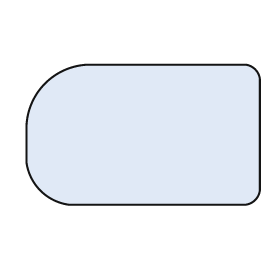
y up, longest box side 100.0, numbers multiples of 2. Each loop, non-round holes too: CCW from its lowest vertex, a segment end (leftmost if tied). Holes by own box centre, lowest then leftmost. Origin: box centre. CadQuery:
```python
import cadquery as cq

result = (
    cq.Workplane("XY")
    .moveTo(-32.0, -30.0)
    .lineTo(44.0, -30.0)
    .threePointArc((48.0, -28.0), (50.0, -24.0))
    .lineTo(50.0, 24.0)
    .threePointArc((48.0, 28.0), (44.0, 30.0))
    .lineTo(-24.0, 30.0)
    .threePointArc((-42.0, 22.0), (-50.0, 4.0))
    .lineTo(-50.0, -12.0)
    .threePointArc((-44.0, -24.0), (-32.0, -30.0))
    .close()
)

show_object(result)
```